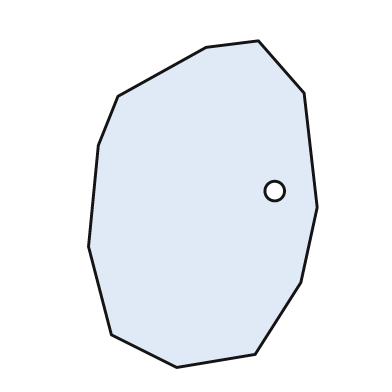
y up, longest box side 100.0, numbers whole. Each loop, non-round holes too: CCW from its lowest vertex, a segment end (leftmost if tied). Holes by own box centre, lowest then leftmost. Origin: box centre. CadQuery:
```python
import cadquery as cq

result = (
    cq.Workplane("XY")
    .moveTo(-8.0, -50.0)
    .lineTo(16.0, -46.0)
    .lineTo(30.0, -24.0)
    .lineTo(35.0, -1.0)
    .lineTo(31.0, 34.0)
    .lineTo(17.0, 50.0)
    .lineTo(1.0, 48.0)
    .lineTo(-26.0, 33.0)
    .lineTo(-32.0, 18.0)
    .lineTo(-35.0, -13.0)
    .lineTo(-28.0, -40.0)
    .close()
    .moveTo(22.0, 4.0)
    .circle(3.0)
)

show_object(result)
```